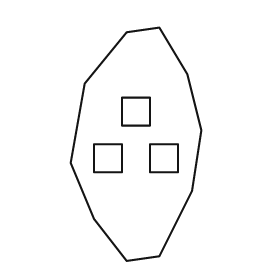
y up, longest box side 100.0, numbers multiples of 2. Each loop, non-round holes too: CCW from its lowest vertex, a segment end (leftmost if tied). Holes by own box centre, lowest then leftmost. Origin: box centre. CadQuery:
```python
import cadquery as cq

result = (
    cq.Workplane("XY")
    .moveTo(-4.0, -50.0)
    .lineTo(10.0, -48.0)
    .lineTo(24.0, -20.0)
    .lineTo(28.0, 6.0)
    .lineTo(22.0, 30.0)
    .lineTo(10.0, 50.0)
    .lineTo(-4.0, 48.0)
    .lineTo(-22.0, 26.0)
    .lineTo(-28.0, -8.0)
    .lineTo(-18.0, -32.0)
    .close()
    .moveTo(-18.0, -12.0)
    .lineTo(-6.0, -12.0)
    .lineTo(-6.0, 0.0)
    .lineTo(-18.0, 0.0)
    .close()
    .moveTo(6.0, -12.0)
    .lineTo(18.0, -12.0)
    .lineTo(18.0, 0.0)
    .lineTo(6.0, 0.0)
    .close()
    .moveTo(-6.0, 8.0)
    .lineTo(6.0, 8.0)
    .lineTo(6.0, 20.0)
    .lineTo(-6.0, 20.0)
    .close()
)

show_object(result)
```